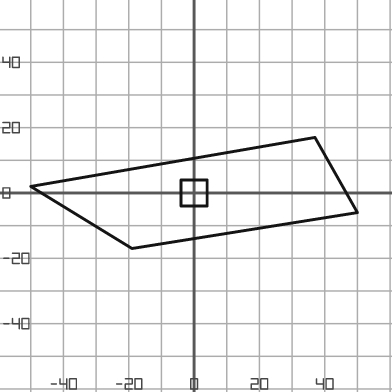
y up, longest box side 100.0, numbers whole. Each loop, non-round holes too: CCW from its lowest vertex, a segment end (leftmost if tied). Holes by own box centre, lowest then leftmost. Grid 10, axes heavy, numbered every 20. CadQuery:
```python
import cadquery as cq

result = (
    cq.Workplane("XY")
    .moveTo(-19.0, -17.0)
    .lineTo(50.0, -6.0)
    .lineTo(37.0, 17.0)
    .lineTo(-50.0, 2.0)
    .close()
    .moveTo(-4.0, -4.0)
    .lineTo(4.0, -4.0)
    .lineTo(4.0, 4.0)
    .lineTo(-4.0, 4.0)
    .close()
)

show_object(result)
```